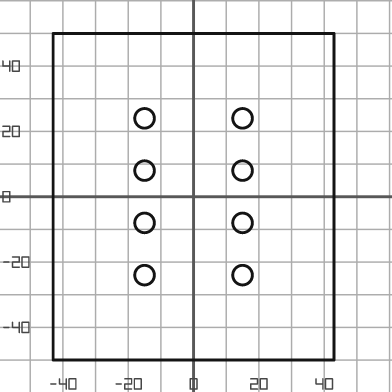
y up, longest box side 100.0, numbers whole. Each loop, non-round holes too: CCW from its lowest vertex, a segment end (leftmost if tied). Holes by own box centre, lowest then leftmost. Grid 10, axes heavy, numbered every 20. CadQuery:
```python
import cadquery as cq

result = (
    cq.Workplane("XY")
    .moveTo(-43.0, -50.0)
    .lineTo(43.0, -50.0)
    .lineTo(43.0, 50.0)
    .lineTo(-43.0, 50.0)
    .close()
    .moveTo(-15.0, -24.0)
    .circle(3.0)
    .moveTo(15.0, -24.0)
    .circle(3.0)
    .moveTo(-15.0, -8.0)
    .circle(3.0)
    .moveTo(15.0, -8.0)
    .circle(3.0)
    .moveTo(-15.0, 8.0)
    .circle(3.0)
    .moveTo(15.0, 8.0)
    .circle(3.0)
    .moveTo(-15.0, 24.0)
    .circle(3.0)
    .moveTo(15.0, 24.0)
    .circle(3.0)
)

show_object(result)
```